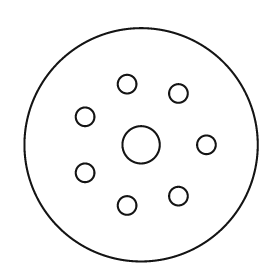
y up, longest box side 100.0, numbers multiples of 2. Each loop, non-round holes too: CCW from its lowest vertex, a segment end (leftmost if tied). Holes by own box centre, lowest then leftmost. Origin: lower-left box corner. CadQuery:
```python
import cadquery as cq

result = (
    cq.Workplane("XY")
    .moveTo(50.0, 50.0)
    .circle(50.0)
    .moveTo(44.0, 24.0)
    .circle(4.0)
    .moveTo(66.0, 28.0)
    .circle(4.0)
    .moveTo(26.0, 38.0)
    .circle(4.0)
    .moveTo(50.0, 50.0)
    .circle(8.0)
    .moveTo(78.0, 50.0)
    .circle(4.0)
    .moveTo(26.0, 62.0)
    .circle(4.0)
    .moveTo(66.0, 72.0)
    .circle(4.0)
    .moveTo(44.0, 76.0)
    .circle(4.0)
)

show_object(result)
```